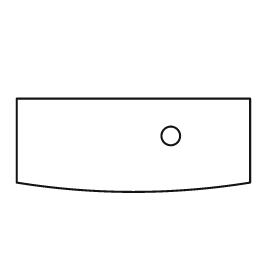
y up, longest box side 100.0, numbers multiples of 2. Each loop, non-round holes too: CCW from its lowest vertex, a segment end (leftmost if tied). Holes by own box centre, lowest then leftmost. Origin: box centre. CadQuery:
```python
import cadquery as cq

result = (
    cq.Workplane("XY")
    .moveTo(-50.0, -16.0)
    .threePointArc((0.0, -20.0), (50.0, -16.0))
    .lineTo(50.0, 20.0)
    .lineTo(-50.0, 20.0)
    .close()
    .moveTo(16.0, 4.0)
    .circle(4.0)
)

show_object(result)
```